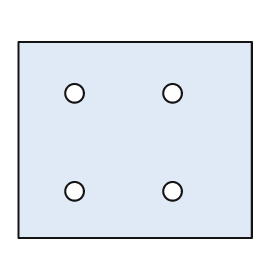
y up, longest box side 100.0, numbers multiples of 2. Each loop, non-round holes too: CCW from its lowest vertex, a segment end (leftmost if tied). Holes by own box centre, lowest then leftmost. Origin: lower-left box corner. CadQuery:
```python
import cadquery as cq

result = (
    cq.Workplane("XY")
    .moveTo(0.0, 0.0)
    .lineTo(100.0, 0.0)
    .lineTo(100.0, 84.0)
    .lineTo(0.0, 84.0)
    .close()
    .moveTo(24.0, 20.0)
    .circle(4.0)
    .moveTo(66.0, 20.0)
    .circle(4.0)
    .moveTo(24.0, 62.0)
    .circle(4.0)
    .moveTo(66.0, 62.0)
    .circle(4.0)
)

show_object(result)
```